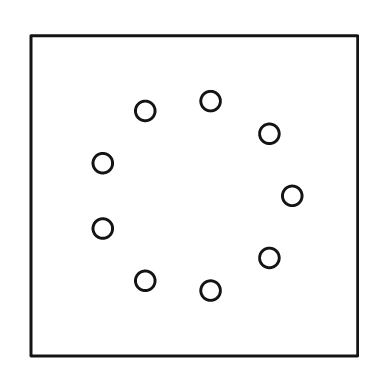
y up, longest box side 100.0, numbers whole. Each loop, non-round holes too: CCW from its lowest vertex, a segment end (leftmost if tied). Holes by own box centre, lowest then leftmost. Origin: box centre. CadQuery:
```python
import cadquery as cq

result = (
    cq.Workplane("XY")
    .moveTo(-50.0, -49.0)
    .lineTo(50.0, -49.0)
    .lineTo(50.0, 49.0)
    .lineTo(-50.0, 49.0)
    .close()
    .moveTo(5.0, -29.0)
    .circle(3.0)
    .moveTo(-15.0, -26.0)
    .circle(3.0)
    .moveTo(23.0, -19.0)
    .circle(3.0)
    .moveTo(-28.0, -10.0)
    .circle(3.0)
    .moveTo(30.0, 0.0)
    .circle(3.0)
    .moveTo(-28.0, 10.0)
    .circle(3.0)
    .moveTo(23.0, 19.0)
    .circle(3.0)
    .moveTo(-15.0, 26.0)
    .circle(3.0)
    .moveTo(5.0, 29.0)
    .circle(3.0)
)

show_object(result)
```